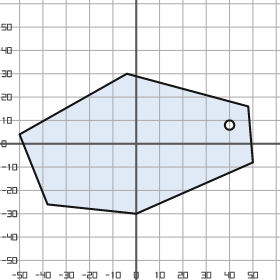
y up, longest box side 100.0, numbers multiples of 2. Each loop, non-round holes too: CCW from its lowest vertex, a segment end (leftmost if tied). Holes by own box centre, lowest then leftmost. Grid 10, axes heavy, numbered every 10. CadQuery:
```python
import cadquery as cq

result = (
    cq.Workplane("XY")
    .moveTo(0.0, -30.0)
    .lineTo(50.0, -8.0)
    .lineTo(48.0, 16.0)
    .lineTo(-4.0, 30.0)
    .lineTo(-50.0, 4.0)
    .lineTo(-38.0, -26.0)
    .close()
    .moveTo(40.0, 8.0)
    .circle(2.0)
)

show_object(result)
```